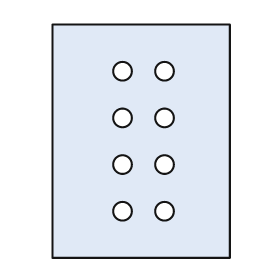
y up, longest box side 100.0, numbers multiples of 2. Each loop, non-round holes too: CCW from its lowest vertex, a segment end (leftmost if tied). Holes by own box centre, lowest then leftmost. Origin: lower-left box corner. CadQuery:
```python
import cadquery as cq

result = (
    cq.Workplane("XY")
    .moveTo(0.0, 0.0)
    .lineTo(76.0, 0.0)
    .lineTo(76.0, 100.0)
    .lineTo(0.0, 100.0)
    .close()
    .moveTo(30.0, 20.0)
    .circle(4.0)
    .moveTo(48.0, 20.0)
    .circle(4.0)
    .moveTo(30.0, 40.0)
    .circle(4.0)
    .moveTo(48.0, 40.0)
    .circle(4.0)
    .moveTo(30.0, 60.0)
    .circle(4.0)
    .moveTo(48.0, 60.0)
    .circle(4.0)
    .moveTo(30.0, 80.0)
    .circle(4.0)
    .moveTo(48.0, 80.0)
    .circle(4.0)
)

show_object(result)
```